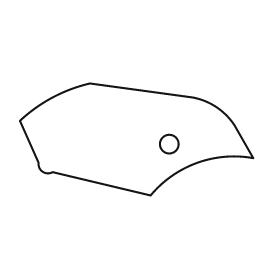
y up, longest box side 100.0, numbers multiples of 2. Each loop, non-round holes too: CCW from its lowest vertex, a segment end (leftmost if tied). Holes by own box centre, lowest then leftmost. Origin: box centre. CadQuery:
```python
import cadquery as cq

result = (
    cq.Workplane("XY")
    .moveTo(6.0, -24.0)
    .threePointArc((26.0, -10.0), (50.0, -8.0))
    .lineTo(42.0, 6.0)
    .threePointArc((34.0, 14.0), (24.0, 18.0))
    .lineTo(-20.0, 24.0)
    .threePointArc((-36.0, 18.0), (-50.0, 8.0))
    .lineTo(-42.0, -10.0)
    .threePointArc((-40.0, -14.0), (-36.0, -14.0))
    .close()
    .moveTo(14.0, -2.0)
    .circle(4.0)
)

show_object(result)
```